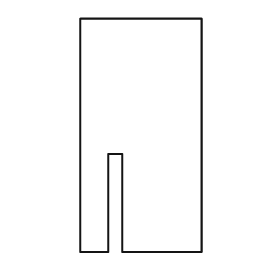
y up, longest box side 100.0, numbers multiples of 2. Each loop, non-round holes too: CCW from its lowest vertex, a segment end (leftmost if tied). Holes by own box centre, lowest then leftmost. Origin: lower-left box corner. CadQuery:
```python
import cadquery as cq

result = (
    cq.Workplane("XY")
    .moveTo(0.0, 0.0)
    .lineTo(12.0, 0.0)
    .lineTo(12.0, 42.0)
    .lineTo(18.0, 42.0)
    .lineTo(18.0, 0.0)
    .lineTo(52.0, 0.0)
    .lineTo(52.0, 100.0)
    .lineTo(0.0, 100.0)
    .close()
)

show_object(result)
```